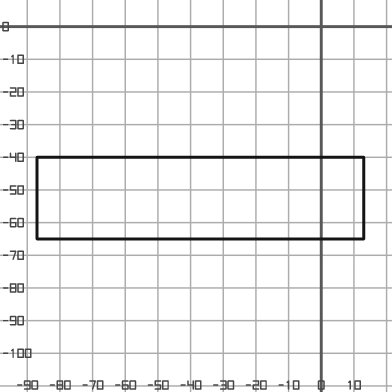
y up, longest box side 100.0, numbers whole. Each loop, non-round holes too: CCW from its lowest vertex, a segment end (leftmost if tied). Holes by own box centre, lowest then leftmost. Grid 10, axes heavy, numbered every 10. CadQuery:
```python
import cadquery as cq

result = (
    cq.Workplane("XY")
    .moveTo(-87.0, -65.0)
    .lineTo(13.0, -65.0)
    .lineTo(13.0, -40.0)
    .lineTo(-87.0, -40.0)
    .close()
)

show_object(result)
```